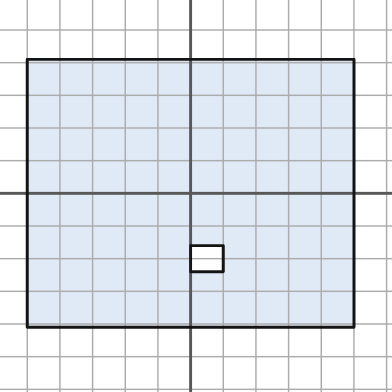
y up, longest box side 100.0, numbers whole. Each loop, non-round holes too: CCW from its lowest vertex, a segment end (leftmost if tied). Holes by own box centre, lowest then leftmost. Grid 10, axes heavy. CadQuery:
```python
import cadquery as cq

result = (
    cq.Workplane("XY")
    .moveTo(-50.0, -41.0)
    .lineTo(50.0, -41.0)
    .lineTo(50.0, 41.0)
    .lineTo(-50.0, 41.0)
    .close()
    .moveTo(0.0, -24.0)
    .lineTo(10.0, -24.0)
    .lineTo(10.0, -16.0)
    .lineTo(0.0, -16.0)
    .close()
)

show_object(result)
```